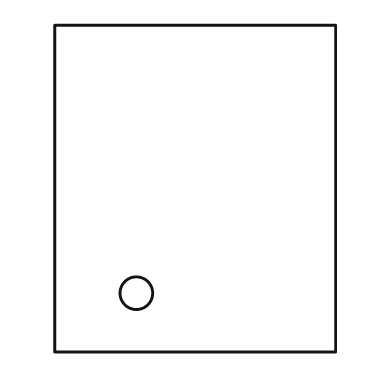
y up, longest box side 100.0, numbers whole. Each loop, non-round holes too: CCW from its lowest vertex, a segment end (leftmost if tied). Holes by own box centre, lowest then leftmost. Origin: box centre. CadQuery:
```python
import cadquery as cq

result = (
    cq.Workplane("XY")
    .moveTo(-43.0, -50.0)
    .lineTo(43.0, -50.0)
    .lineTo(43.0, 50.0)
    .lineTo(-43.0, 50.0)
    .close()
    .moveTo(-18.0, -32.0)
    .circle(5.0)
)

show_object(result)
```